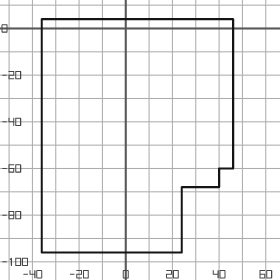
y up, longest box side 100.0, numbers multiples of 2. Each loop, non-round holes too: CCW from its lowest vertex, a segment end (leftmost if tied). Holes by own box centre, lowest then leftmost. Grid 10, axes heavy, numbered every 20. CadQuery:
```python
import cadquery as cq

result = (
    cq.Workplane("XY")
    .moveTo(-36.0, -96.0)
    .lineTo(24.0, -96.0)
    .lineTo(24.0, -68.0)
    .lineTo(40.0, -68.0)
    .lineTo(40.0, -60.0)
    .lineTo(46.0, -60.0)
    .lineTo(46.0, 4.0)
    .lineTo(-36.0, 4.0)
    .close()
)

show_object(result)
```